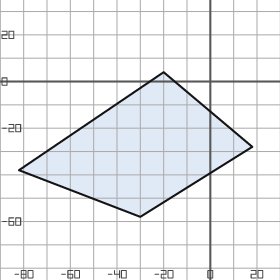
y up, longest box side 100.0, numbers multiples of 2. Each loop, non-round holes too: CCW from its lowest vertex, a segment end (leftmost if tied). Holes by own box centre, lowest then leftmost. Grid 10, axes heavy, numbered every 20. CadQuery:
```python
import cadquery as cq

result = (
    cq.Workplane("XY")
    .moveTo(-30.0, -58.0)
    .lineTo(18.0, -28.0)
    .lineTo(-20.0, 4.0)
    .lineTo(-82.0, -38.0)
    .close()
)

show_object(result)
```